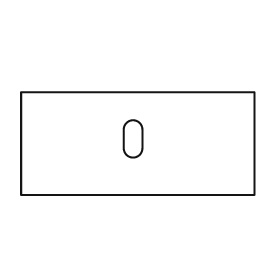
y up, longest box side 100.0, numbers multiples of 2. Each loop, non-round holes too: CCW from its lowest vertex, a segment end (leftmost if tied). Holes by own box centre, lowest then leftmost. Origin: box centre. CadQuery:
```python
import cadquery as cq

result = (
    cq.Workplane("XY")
    .moveTo(-50.0, -22.0)
    .lineTo(50.0, -22.0)
    .lineTo(50.0, 22.0)
    .lineTo(-50.0, 22.0)
    .close()
    .moveTo(-6.0, -2.0)
    .threePointArc((-2.0, -6.0), (2.0, -2.0))
    .lineTo(2.0, 6.0)
    .threePointArc((-2.0, 10.0), (-6.0, 6.0))
    .close()
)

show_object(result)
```